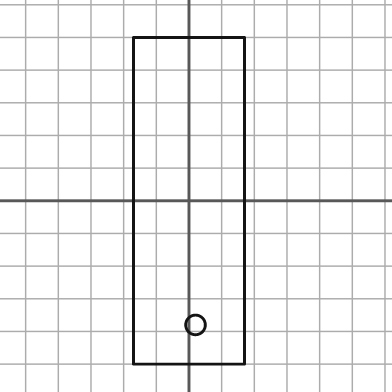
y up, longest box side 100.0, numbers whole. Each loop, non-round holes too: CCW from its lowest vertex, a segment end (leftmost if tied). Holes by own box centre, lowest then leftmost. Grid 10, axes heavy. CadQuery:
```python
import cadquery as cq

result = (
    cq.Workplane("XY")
    .moveTo(-17.0, -50.0)
    .lineTo(17.0, -50.0)
    .lineTo(17.0, 50.0)
    .lineTo(-17.0, 50.0)
    .close()
    .moveTo(2.0, -38.0)
    .circle(3.0)
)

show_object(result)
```